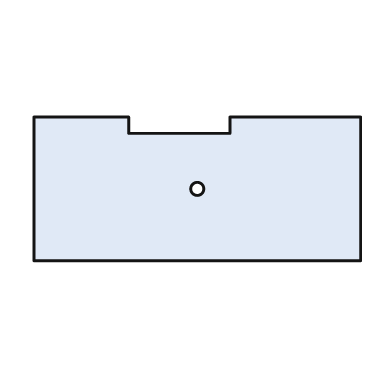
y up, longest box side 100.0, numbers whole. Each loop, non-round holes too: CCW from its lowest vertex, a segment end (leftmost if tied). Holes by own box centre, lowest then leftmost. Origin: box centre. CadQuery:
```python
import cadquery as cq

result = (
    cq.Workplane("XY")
    .moveTo(-50.0, -22.0)
    .lineTo(50.0, -22.0)
    .lineTo(50.0, 22.0)
    .lineTo(10.0, 22.0)
    .lineTo(10.0, 17.0)
    .lineTo(-21.0, 17.0)
    .lineTo(-21.0, 22.0)
    .lineTo(-50.0, 22.0)
    .close()
    .moveTo(0.0, 0.0)
    .circle(2.0)
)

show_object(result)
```